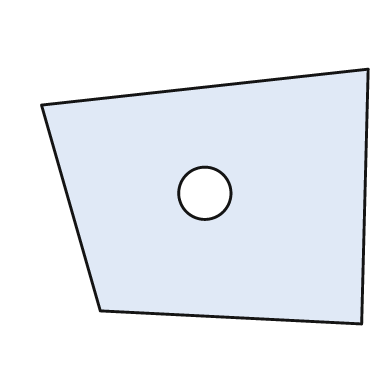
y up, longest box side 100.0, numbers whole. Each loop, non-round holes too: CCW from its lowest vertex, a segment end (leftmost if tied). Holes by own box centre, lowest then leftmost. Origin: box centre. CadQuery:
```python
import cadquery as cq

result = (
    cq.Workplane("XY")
    .moveTo(48.0, -39.0)
    .lineTo(50.0, 39.0)
    .lineTo(-50.0, 28.0)
    .lineTo(-32.0, -35.0)
    .close()
    .moveTo(0.0, 1.0)
    .circle(8.0)
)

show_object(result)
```